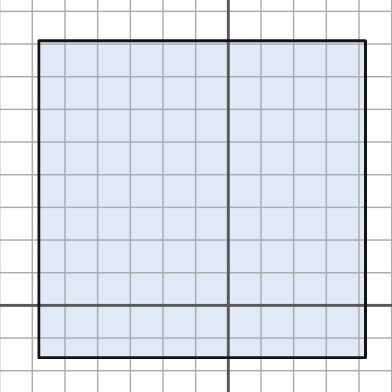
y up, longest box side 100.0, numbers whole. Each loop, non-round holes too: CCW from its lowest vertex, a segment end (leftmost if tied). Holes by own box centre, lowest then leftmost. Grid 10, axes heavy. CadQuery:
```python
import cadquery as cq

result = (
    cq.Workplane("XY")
    .moveTo(-58.0, -16.0)
    .lineTo(42.0, -16.0)
    .lineTo(42.0, 81.0)
    .lineTo(-58.0, 81.0)
    .close()
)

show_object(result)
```